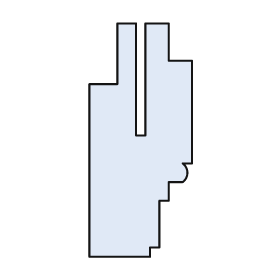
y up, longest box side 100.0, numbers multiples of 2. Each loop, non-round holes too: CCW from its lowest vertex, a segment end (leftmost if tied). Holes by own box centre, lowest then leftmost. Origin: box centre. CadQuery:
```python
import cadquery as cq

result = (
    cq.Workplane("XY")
    .moveTo(-22.0, -50.0)
    .lineTo(4.0, -50.0)
    .lineTo(4.0, -46.0)
    .lineTo(8.0, -46.0)
    .lineTo(8.0, -26.0)
    .lineTo(12.0, -26.0)
    .lineTo(12.0, -18.0)
    .lineTo(18.0, -18.0)
    .threePointArc((20.0, -14.0), (18.0, -10.0))
    .lineTo(22.0, -10.0)
    .lineTo(22.0, 34.0)
    .lineTo(12.0, 34.0)
    .lineTo(12.0, 50.0)
    .lineTo(2.0, 50.0)
    .lineTo(2.0, 2.0)
    .lineTo(-2.0, 2.0)
    .lineTo(-2.0, 50.0)
    .lineTo(-10.0, 50.0)
    .lineTo(-10.0, 24.0)
    .lineTo(-22.0, 24.0)
    .close()
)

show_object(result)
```